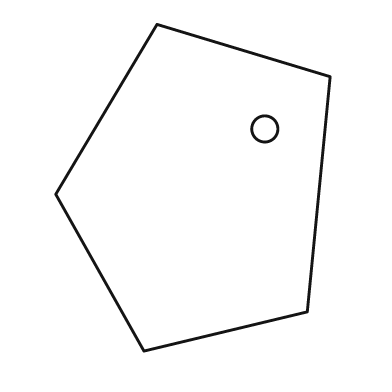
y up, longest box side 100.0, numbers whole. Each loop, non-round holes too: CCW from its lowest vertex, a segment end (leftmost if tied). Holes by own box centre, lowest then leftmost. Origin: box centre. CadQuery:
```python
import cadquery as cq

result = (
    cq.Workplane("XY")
    .moveTo(-15.0, -50.0)
    .lineTo(35.0, -38.0)
    .lineTo(42.0, 34.0)
    .lineTo(-11.0, 50.0)
    .lineTo(-42.0, -2.0)
    .close()
    .moveTo(22.0, 18.0)
    .circle(4.0)
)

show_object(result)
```